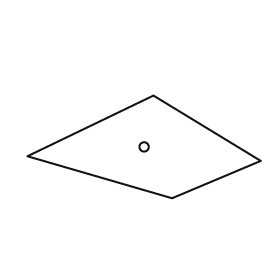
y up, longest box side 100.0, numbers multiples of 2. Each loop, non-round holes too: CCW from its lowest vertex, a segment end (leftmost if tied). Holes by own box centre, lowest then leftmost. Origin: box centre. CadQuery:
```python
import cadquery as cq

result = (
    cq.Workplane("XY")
    .moveTo(12.0, -22.0)
    .lineTo(50.0, -6.0)
    .lineTo(4.0, 22.0)
    .lineTo(-50.0, -4.0)
    .close()
    .moveTo(0.0, 0.0)
    .circle(2.0)
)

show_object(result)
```